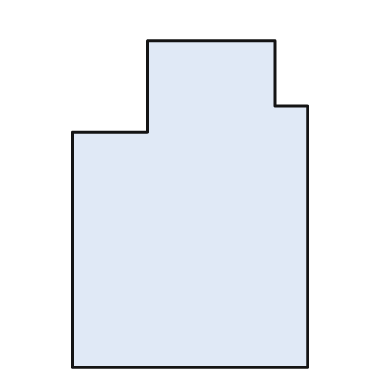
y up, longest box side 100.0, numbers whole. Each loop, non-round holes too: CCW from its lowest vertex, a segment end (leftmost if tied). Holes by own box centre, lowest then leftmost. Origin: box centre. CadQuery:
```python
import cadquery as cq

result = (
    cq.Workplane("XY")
    .moveTo(-36.0, -50.0)
    .lineTo(36.0, -50.0)
    .lineTo(36.0, 30.0)
    .lineTo(26.0, 30.0)
    .lineTo(26.0, 50.0)
    .lineTo(-13.0, 50.0)
    .lineTo(-13.0, 22.0)
    .lineTo(-36.0, 22.0)
    .close()
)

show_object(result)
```